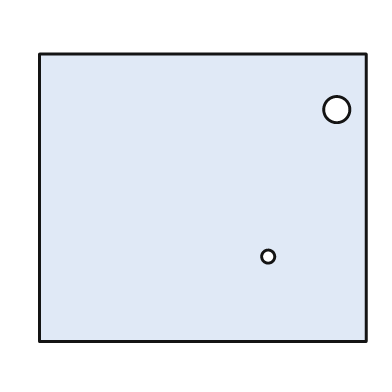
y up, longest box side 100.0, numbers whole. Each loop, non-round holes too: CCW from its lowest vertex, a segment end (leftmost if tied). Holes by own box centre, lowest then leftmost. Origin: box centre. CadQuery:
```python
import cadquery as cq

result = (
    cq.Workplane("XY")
    .moveTo(-50.0, -44.0)
    .lineTo(50.0, -44.0)
    .lineTo(50.0, 44.0)
    .lineTo(-50.0, 44.0)
    .close()
    .moveTo(20.0, -18.0)
    .circle(2.0)
    .moveTo(41.0, 27.0)
    .circle(4.0)
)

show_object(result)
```